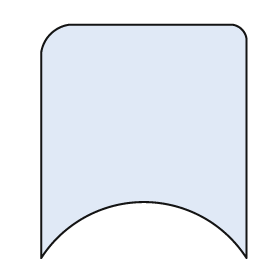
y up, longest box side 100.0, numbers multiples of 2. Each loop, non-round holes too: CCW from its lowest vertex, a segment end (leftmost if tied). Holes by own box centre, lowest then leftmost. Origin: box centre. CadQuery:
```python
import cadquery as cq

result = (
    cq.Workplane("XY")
    .moveTo(-44.0, -50.0)
    .threePointArc((0.0, -26.0), (44.0, -50.0))
    .lineTo(44.0, 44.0)
    .threePointArc((42.0, 48.0), (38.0, 50.0))
    .lineTo(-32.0, 50.0)
    .threePointArc((-40.0, 46.0), (-44.0, 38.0))
    .close()
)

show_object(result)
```